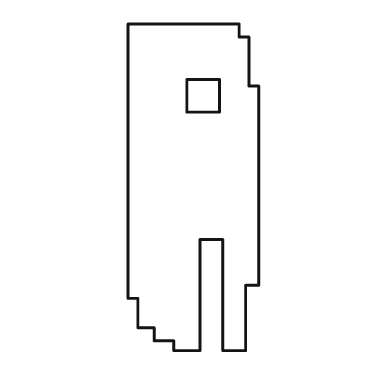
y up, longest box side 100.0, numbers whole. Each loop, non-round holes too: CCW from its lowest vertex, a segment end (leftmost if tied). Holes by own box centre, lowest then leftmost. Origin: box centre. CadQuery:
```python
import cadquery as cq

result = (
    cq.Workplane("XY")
    .moveTo(-6.0, -50.0)
    .lineTo(2.0, -50.0)
    .lineTo(2.0, -16.0)
    .lineTo(9.0, -16.0)
    .lineTo(9.0, -50.0)
    .lineTo(16.0, -50.0)
    .lineTo(16.0, -30.0)
    .lineTo(20.0, -30.0)
    .lineTo(20.0, 31.0)
    .lineTo(17.0, 31.0)
    .lineTo(17.0, 46.0)
    .lineTo(14.0, 46.0)
    .lineTo(14.0, 50.0)
    .lineTo(-20.0, 50.0)
    .lineTo(-20.0, -34.0)
    .lineTo(-17.0, -34.0)
    .lineTo(-17.0, -43.0)
    .lineTo(-12.0, -43.0)
    .lineTo(-12.0, -47.0)
    .lineTo(-6.0, -47.0)
    .close()
    .moveTo(-2.0, 23.0)
    .lineTo(8.0, 23.0)
    .lineTo(8.0, 33.0)
    .lineTo(-2.0, 33.0)
    .close()
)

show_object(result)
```